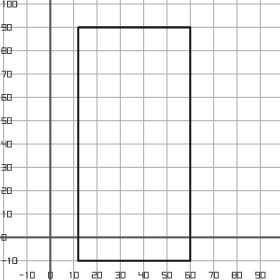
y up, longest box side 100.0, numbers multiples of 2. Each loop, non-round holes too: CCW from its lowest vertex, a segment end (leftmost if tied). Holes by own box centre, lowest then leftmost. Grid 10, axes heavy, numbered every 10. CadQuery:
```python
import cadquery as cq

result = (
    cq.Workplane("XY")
    .moveTo(12.0, -10.0)
    .lineTo(60.0, -10.0)
    .lineTo(60.0, 90.0)
    .lineTo(12.0, 90.0)
    .close()
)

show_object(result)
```